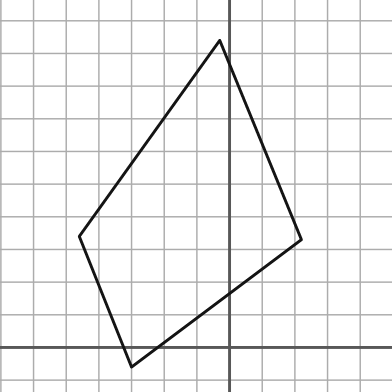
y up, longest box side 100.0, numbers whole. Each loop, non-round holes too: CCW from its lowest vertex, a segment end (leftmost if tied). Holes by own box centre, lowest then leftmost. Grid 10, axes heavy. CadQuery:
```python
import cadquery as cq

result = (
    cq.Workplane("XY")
    .moveTo(-30.0, -6.0)
    .lineTo(22.0, 33.0)
    .lineTo(-3.0, 94.0)
    .lineTo(-46.0, 34.0)
    .close()
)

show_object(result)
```